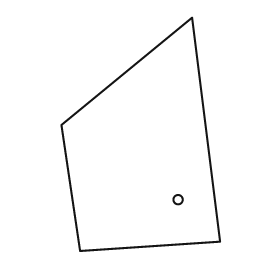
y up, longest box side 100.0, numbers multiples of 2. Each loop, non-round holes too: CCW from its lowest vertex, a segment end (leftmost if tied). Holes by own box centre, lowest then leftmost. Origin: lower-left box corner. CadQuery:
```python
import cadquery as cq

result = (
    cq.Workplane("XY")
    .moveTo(8.0, 0.0)
    .lineTo(68.0, 4.0)
    .lineTo(56.0, 100.0)
    .lineTo(0.0, 54.0)
    .close()
    .moveTo(50.0, 22.0)
    .circle(2.0)
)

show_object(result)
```